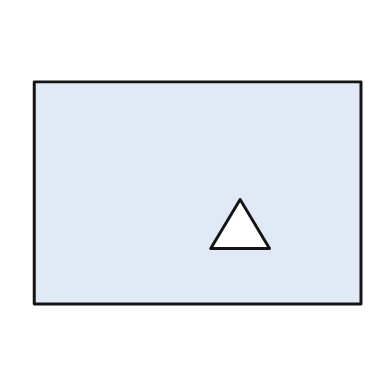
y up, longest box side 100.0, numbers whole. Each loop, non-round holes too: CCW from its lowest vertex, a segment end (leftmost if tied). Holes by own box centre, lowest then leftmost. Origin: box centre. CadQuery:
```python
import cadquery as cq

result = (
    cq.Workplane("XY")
    .moveTo(-50.0, -34.0)
    .lineTo(50.0, -34.0)
    .lineTo(50.0, 34.0)
    .lineTo(-50.0, 34.0)
    .close()
    .moveTo(4.0, -17.0)
    .lineTo(22.0, -17.0)
    .lineTo(13.0, -2.0)
    .close()
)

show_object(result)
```